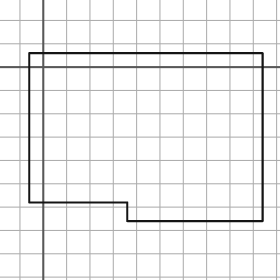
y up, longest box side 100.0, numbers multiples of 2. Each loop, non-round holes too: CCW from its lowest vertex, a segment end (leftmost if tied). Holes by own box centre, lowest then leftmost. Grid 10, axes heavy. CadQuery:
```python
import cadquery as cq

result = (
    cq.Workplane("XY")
    .moveTo(36.0, -66.0)
    .lineTo(94.0, -66.0)
    .lineTo(94.0, 6.0)
    .lineTo(-6.0, 6.0)
    .lineTo(-6.0, -58.0)
    .lineTo(36.0, -58.0)
    .close()
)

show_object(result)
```